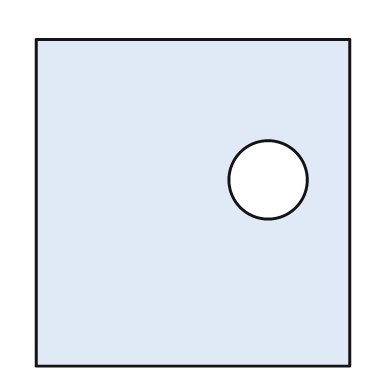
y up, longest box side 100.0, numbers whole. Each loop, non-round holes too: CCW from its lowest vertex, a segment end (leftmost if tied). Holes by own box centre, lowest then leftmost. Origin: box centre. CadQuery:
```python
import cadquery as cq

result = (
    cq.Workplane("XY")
    .moveTo(-48.0, -50.0)
    .lineTo(48.0, -50.0)
    .lineTo(48.0, 50.0)
    .lineTo(-48.0, 50.0)
    .close()
    .moveTo(23.0, 7.0)
    .circle(12.0)
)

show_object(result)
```